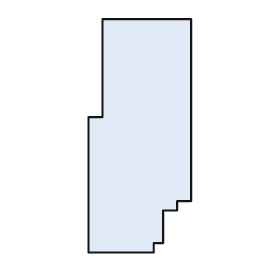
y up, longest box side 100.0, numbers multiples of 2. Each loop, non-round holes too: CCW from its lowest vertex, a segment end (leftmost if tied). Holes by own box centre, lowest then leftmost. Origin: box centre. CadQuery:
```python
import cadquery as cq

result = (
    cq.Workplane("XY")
    .moveTo(-22.0, -50.0)
    .lineTo(6.0, -50.0)
    .lineTo(6.0, -46.0)
    .lineTo(10.0, -46.0)
    .lineTo(10.0, -32.0)
    .lineTo(16.0, -32.0)
    .lineTo(16.0, -28.0)
    .lineTo(22.0, -28.0)
    .lineTo(22.0, 50.0)
    .lineTo(-16.0, 50.0)
    .lineTo(-16.0, 8.0)
    .lineTo(-22.0, 8.0)
    .close()
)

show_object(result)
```